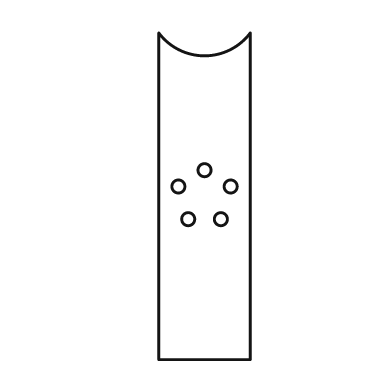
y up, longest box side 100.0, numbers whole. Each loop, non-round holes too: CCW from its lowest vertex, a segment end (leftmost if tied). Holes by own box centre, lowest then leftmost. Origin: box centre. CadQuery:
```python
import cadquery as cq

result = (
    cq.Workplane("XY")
    .moveTo(-14.0, -50.0)
    .lineTo(14.0, -50.0)
    .lineTo(14.0, 50.0)
    .threePointArc((0.0, 43.0), (-14.0, 50.0))
    .close()
    .moveTo(-5.0, -7.0)
    .circle(2.0)
    .moveTo(5.0, -7.0)
    .circle(2.0)
    .moveTo(-8.0, 3.0)
    .circle(2.0)
    .moveTo(8.0, 3.0)
    .circle(2.0)
    .moveTo(0.0, 8.0)
    .circle(2.0)
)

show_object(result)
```